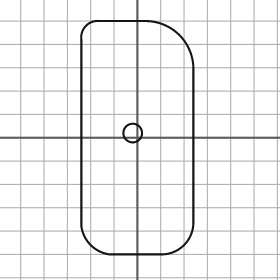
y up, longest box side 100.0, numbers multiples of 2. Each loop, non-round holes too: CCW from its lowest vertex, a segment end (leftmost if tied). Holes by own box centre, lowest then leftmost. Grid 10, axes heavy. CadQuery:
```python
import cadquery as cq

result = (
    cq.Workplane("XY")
    .moveTo(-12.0, -50.0)
    .lineTo(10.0, -50.0)
    .threePointArc((20.0, -46.0), (24.0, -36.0))
    .lineTo(24.0, 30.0)
    .threePointArc((18.0, 44.0), (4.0, 50.0))
    .lineTo(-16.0, 50.0)
    .threePointArc((-22.0, 48.0), (-24.0, 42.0))
    .lineTo(-24.0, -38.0)
    .threePointArc((-20.0, -46.0), (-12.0, -50.0))
    .close()
    .moveTo(-2.0, 2.0)
    .circle(4.0)
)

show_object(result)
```